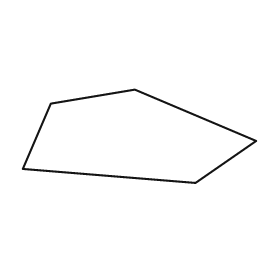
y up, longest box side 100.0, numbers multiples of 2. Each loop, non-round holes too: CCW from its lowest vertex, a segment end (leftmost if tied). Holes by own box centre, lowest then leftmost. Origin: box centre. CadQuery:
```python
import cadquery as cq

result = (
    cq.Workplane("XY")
    .moveTo(24.0, -20.0)
    .lineTo(50.0, -2.0)
    .lineTo(-2.0, 20.0)
    .lineTo(-38.0, 14.0)
    .lineTo(-50.0, -14.0)
    .close()
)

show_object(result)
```